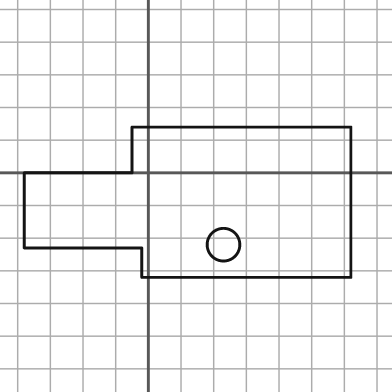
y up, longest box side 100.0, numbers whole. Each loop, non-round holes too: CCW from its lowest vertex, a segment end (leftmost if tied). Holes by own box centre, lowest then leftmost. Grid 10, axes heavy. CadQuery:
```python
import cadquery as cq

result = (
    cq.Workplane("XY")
    .moveTo(-2.0, -32.0)
    .lineTo(62.0, -32.0)
    .lineTo(62.0, 14.0)
    .lineTo(-5.0, 14.0)
    .lineTo(-5.0, 0.0)
    .lineTo(-38.0, 0.0)
    .lineTo(-38.0, -23.0)
    .lineTo(-2.0, -23.0)
    .close()
    .moveTo(23.0, -22.0)
    .circle(5.0)
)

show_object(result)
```